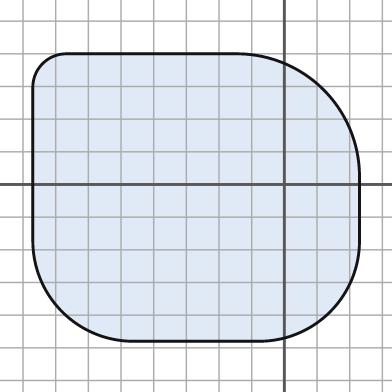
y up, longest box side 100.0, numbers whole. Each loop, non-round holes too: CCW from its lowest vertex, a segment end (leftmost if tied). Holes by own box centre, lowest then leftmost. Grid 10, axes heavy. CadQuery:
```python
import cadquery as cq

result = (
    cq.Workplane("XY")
    .moveTo(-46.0, -48.0)
    .lineTo(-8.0, -48.0)
    .threePointArc((14.0, -39.0), (23.0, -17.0))
    .lineTo(23.0, 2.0)
    .threePointArc((12.0, 29.0), (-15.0, 40.0))
    .lineTo(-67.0, 40.0)
    .threePointArc((-74.0, 37.0), (-77.0, 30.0))
    .lineTo(-77.0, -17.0)
    .threePointArc((-68.0, -39.0), (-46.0, -48.0))
    .close()
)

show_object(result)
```